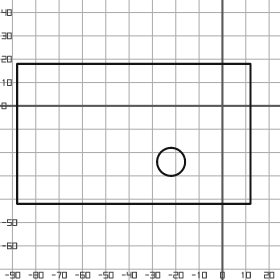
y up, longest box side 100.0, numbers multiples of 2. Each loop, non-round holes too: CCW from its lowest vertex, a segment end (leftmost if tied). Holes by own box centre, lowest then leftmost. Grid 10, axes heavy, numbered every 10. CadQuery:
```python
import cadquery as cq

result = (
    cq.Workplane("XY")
    .moveTo(-88.0, -42.0)
    .lineTo(12.0, -42.0)
    .lineTo(12.0, 18.0)
    .lineTo(-88.0, 18.0)
    .close()
    .moveTo(-22.0, -24.0)
    .circle(6.0)
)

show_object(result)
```